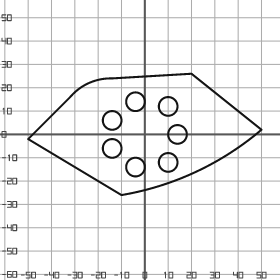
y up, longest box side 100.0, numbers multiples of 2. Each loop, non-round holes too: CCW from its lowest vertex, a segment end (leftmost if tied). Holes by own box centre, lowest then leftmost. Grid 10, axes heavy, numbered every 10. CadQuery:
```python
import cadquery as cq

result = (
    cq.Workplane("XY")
    .moveTo(-10.0, -26.0)
    .threePointArc((22.0, -16.0), (50.0, 2.0))
    .lineTo(20.0, 26.0)
    .lineTo(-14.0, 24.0)
    .threePointArc((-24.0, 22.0), (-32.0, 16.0))
    .lineTo(-50.0, -2.0)
    .close()
    .moveTo(-4.0, -14.0)
    .circle(4.0)
    .moveTo(10.0, -12.0)
    .circle(4.0)
    .moveTo(-14.0, -6.0)
    .circle(4.0)
    .moveTo(14.0, 0.0)
    .circle(4.0)
    .moveTo(-14.0, 6.0)
    .circle(4.0)
    .moveTo(10.0, 12.0)
    .circle(4.0)
    .moveTo(-4.0, 14.0)
    .circle(4.0)
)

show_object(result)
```